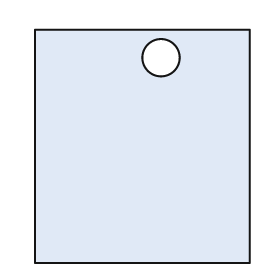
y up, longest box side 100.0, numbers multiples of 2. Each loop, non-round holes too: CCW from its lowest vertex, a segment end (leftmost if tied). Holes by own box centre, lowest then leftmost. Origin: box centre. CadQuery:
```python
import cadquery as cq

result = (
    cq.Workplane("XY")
    .moveTo(-46.0, -50.0)
    .lineTo(46.0, -50.0)
    .lineTo(46.0, 50.0)
    .lineTo(-46.0, 50.0)
    .close()
    .moveTo(8.0, 38.0)
    .circle(8.0)
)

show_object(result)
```